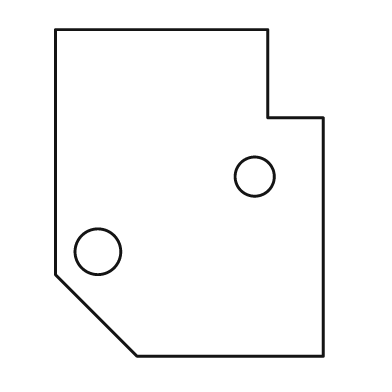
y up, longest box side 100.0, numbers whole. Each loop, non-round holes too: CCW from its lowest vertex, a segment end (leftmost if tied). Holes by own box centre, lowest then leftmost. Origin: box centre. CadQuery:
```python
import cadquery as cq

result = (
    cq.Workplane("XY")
    .moveTo(-16.0, -50.0)
    .lineTo(41.0, -50.0)
    .lineTo(41.0, 23.0)
    .lineTo(24.0, 23.0)
    .lineTo(24.0, 50.0)
    .lineTo(-41.0, 50.0)
    .lineTo(-41.0, -25.0)
    .close()
    .moveTo(-28.0, -18.0)
    .circle(7.0)
    .moveTo(20.0, 5.0)
    .circle(6.0)
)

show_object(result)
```